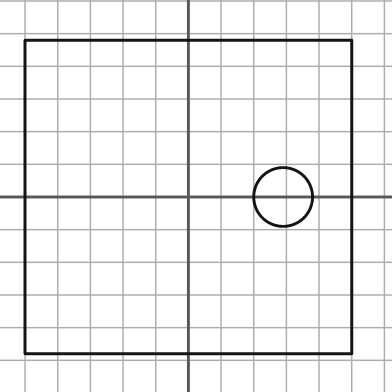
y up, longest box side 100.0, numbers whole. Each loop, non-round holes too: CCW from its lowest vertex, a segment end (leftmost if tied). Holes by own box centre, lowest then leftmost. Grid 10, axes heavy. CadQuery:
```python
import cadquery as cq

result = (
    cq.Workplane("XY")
    .moveTo(-50.0, -48.0)
    .lineTo(50.0, -48.0)
    .lineTo(50.0, 48.0)
    .lineTo(-50.0, 48.0)
    .close()
    .moveTo(29.0, 0.0)
    .circle(9.0)
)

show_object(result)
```